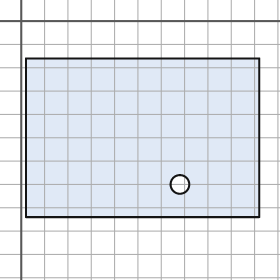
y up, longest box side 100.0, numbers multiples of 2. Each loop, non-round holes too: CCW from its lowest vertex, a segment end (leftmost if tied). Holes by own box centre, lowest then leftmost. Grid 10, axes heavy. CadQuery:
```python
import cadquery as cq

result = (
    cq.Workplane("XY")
    .moveTo(2.0, -84.0)
    .lineTo(102.0, -84.0)
    .lineTo(102.0, -16.0)
    .lineTo(2.0, -16.0)
    .close()
    .moveTo(68.0, -70.0)
    .circle(4.0)
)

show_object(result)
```